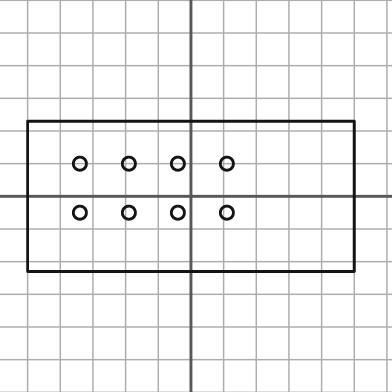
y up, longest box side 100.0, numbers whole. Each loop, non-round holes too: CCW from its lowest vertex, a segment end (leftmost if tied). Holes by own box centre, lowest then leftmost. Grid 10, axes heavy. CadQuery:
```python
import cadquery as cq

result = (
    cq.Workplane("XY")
    .moveTo(-50.0, -23.0)
    .lineTo(50.0, -23.0)
    .lineTo(50.0, 23.0)
    .lineTo(-50.0, 23.0)
    .close()
    .moveTo(-34.0, -5.0)
    .circle(2.0)
    .moveTo(-19.0, -5.0)
    .circle(2.0)
    .moveTo(-4.0, -5.0)
    .circle(2.0)
    .moveTo(11.0, -5.0)
    .circle(2.0)
    .moveTo(-34.0, 10.0)
    .circle(2.0)
    .moveTo(-19.0, 10.0)
    .circle(2.0)
    .moveTo(-4.0, 10.0)
    .circle(2.0)
    .moveTo(11.0, 10.0)
    .circle(2.0)
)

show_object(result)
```